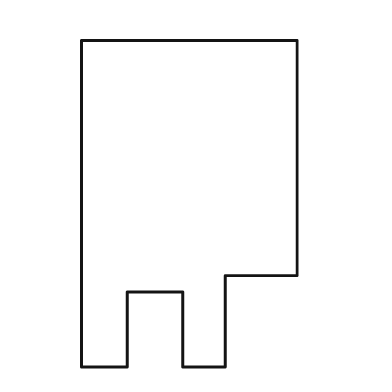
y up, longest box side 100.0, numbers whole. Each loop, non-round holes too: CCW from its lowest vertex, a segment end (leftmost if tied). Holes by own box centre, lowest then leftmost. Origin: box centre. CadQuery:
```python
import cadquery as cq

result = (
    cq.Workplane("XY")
    .moveTo(-33.0, -50.0)
    .lineTo(-19.0, -50.0)
    .lineTo(-19.0, -27.0)
    .lineTo(-2.0, -27.0)
    .lineTo(-2.0, -50.0)
    .lineTo(11.0, -50.0)
    .lineTo(11.0, -22.0)
    .lineTo(33.0, -22.0)
    .lineTo(33.0, 50.0)
    .lineTo(-33.0, 50.0)
    .close()
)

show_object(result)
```